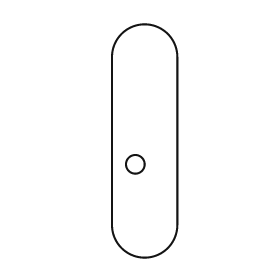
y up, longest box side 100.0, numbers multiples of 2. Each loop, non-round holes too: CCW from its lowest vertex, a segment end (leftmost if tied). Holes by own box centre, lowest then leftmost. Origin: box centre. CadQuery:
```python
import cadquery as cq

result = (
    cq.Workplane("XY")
    .moveTo(-14.0, -36.0)
    .threePointArc((0.0, -50.0), (14.0, -36.0))
    .lineTo(14.0, 36.0)
    .threePointArc((0.0, 50.0), (-14.0, 36.0))
    .close()
    .moveTo(-4.0, -10.0)
    .circle(4.0)
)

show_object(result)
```